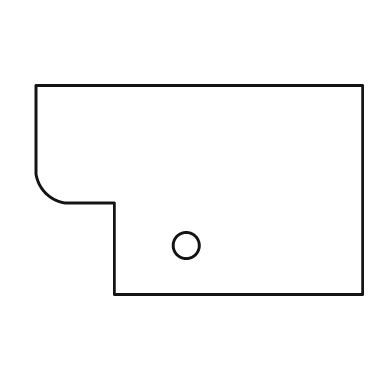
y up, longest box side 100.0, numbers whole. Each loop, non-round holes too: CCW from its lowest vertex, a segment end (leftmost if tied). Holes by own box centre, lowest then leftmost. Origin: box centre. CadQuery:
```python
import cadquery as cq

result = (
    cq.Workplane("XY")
    .moveTo(-26.0, -32.0)
    .lineTo(50.0, -32.0)
    .lineTo(50.0, 32.0)
    .lineTo(-50.0, 32.0)
    .lineTo(-50.0, 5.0)
    .threePointArc((-47.0, -1.0), (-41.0, -4.0))
    .lineTo(-26.0, -4.0)
    .close()
    .moveTo(-4.0, -17.0)
    .circle(4.0)
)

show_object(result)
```